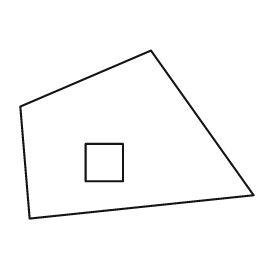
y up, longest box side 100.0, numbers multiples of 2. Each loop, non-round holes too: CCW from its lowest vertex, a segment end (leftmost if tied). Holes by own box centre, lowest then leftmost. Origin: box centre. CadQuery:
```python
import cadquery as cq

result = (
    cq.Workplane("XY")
    .moveTo(-46.0, -36.0)
    .lineTo(50.0, -26.0)
    .lineTo(6.0, 36.0)
    .lineTo(-50.0, 12.0)
    .close()
    .moveTo(-22.0, -20.0)
    .lineTo(-6.0, -20.0)
    .lineTo(-6.0, -4.0)
    .lineTo(-22.0, -4.0)
    .close()
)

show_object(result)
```